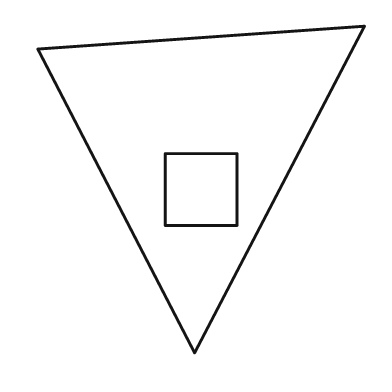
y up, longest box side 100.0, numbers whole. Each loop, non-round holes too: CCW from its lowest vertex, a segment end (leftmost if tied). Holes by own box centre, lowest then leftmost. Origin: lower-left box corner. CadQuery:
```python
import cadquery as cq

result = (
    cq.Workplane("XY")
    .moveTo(48.0, 0.0)
    .lineTo(100.0, 100.0)
    .lineTo(0.0, 93.0)
    .close()
    .moveTo(39.0, 39.0)
    .lineTo(61.0, 39.0)
    .lineTo(61.0, 61.0)
    .lineTo(39.0, 61.0)
    .close()
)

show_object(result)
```